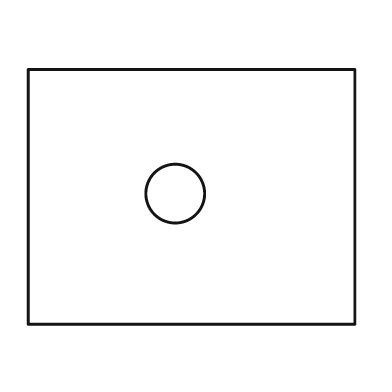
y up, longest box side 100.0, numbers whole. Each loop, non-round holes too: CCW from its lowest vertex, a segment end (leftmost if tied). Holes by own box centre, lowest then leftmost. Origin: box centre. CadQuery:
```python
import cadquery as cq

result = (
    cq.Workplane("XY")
    .moveTo(-50.0, -39.0)
    .lineTo(50.0, -39.0)
    .lineTo(50.0, 39.0)
    .lineTo(-50.0, 39.0)
    .close()
    .moveTo(-5.0, 1.0)
    .circle(9.0)
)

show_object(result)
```